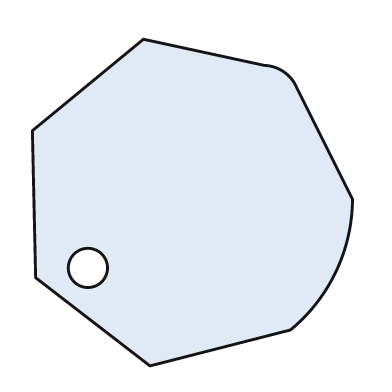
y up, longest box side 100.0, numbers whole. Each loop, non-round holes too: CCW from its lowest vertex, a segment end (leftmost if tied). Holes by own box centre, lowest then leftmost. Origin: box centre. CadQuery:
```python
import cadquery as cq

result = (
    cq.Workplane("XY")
    .moveTo(-13.0, -50.0)
    .lineTo(30.0, -39.0)
    .threePointArc((44.0, -21.0), (49.0, 1.0))
    .lineTo(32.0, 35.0)
    .threePointArc((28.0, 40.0), (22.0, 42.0))
    .lineTo(-15.0, 50.0)
    .lineTo(-49.0, 22.0)
    .lineTo(-48.0, -23.0)
    .close()
    .moveTo(-32.0, -20.0)
    .circle(6.0)
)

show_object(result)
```